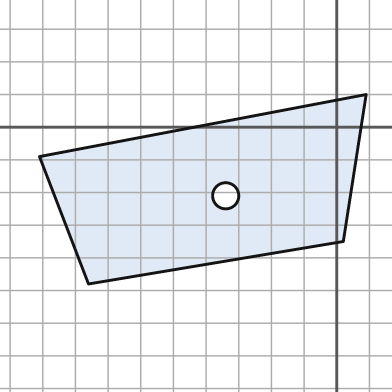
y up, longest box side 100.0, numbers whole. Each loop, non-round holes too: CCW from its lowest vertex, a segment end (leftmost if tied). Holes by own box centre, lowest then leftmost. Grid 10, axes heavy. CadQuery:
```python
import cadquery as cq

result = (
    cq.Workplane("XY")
    .moveTo(-76.0, -48.0)
    .lineTo(2.0, -35.0)
    .lineTo(9.0, 10.0)
    .lineTo(-91.0, -9.0)
    .close()
    .moveTo(-34.0, -21.0)
    .circle(4.0)
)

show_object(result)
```